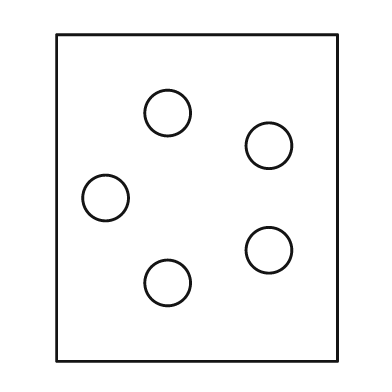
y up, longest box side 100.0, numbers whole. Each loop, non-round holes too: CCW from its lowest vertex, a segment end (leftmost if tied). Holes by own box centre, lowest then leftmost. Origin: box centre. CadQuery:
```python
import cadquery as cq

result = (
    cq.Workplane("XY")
    .moveTo(-43.0, -50.0)
    .lineTo(43.0, -50.0)
    .lineTo(43.0, 50.0)
    .lineTo(-43.0, 50.0)
    .close()
    .moveTo(-9.0, -26.0)
    .circle(7.0)
    .moveTo(22.0, -16.0)
    .circle(7.0)
    .moveTo(-28.0, 0.0)
    .circle(7.0)
    .moveTo(22.0, 16.0)
    .circle(7.0)
    .moveTo(-9.0, 26.0)
    .circle(7.0)
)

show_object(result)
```